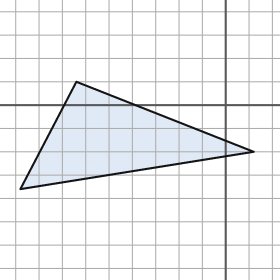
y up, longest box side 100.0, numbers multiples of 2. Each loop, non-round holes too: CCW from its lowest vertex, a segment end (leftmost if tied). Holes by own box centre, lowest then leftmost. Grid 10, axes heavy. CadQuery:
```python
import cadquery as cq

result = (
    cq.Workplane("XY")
    .moveTo(-88.0, -36.0)
    .lineTo(12.0, -20.0)
    .lineTo(-64.0, 10.0)
    .close()
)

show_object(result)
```